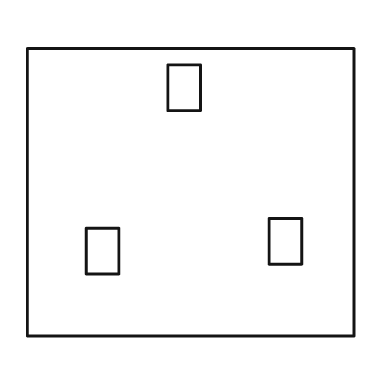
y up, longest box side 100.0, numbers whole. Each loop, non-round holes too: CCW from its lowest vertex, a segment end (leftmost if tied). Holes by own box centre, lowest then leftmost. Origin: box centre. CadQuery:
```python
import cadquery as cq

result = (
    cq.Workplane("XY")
    .moveTo(-50.0, -44.0)
    .lineTo(50.0, -44.0)
    .lineTo(50.0, 44.0)
    .lineTo(-50.0, 44.0)
    .close()
    .moveTo(-32.0, -25.0)
    .lineTo(-22.0, -25.0)
    .lineTo(-22.0, -11.0)
    .lineTo(-32.0, -11.0)
    .close()
    .moveTo(24.0, -22.0)
    .lineTo(34.0, -22.0)
    .lineTo(34.0, -8.0)
    .lineTo(24.0, -8.0)
    .close()
    .moveTo(-7.0, 25.0)
    .lineTo(3.0, 25.0)
    .lineTo(3.0, 39.0)
    .lineTo(-7.0, 39.0)
    .close()
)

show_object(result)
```